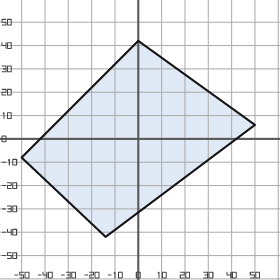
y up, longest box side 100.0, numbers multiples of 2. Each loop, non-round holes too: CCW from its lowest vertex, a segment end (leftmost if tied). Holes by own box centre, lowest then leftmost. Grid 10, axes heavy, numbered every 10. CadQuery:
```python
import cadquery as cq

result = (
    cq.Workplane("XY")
    .moveTo(-14.0, -42.0)
    .lineTo(50.0, 6.0)
    .lineTo(0.0, 42.0)
    .lineTo(-50.0, -8.0)
    .close()
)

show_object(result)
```